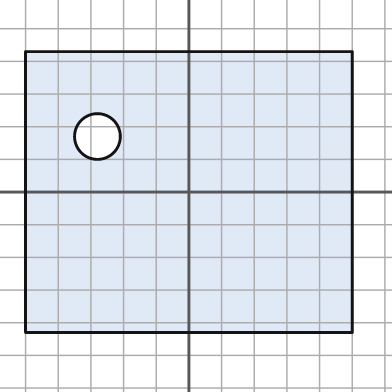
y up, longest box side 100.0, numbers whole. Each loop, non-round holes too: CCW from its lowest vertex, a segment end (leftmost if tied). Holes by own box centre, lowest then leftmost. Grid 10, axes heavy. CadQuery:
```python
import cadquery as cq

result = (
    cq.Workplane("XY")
    .moveTo(-50.0, -43.0)
    .lineTo(50.0, -43.0)
    .lineTo(50.0, 43.0)
    .lineTo(-50.0, 43.0)
    .close()
    .moveTo(-28.0, 17.0)
    .circle(7.0)
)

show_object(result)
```